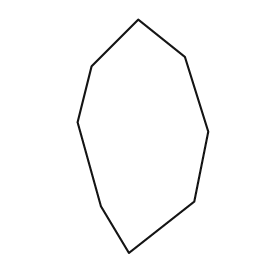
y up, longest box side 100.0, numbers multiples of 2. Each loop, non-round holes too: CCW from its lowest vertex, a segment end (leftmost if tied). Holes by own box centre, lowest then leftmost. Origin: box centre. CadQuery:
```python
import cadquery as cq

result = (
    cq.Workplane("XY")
    .moveTo(-6.0, -50.0)
    .lineTo(22.0, -28.0)
    .lineTo(28.0, 2.0)
    .lineTo(18.0, 34.0)
    .lineTo(-2.0, 50.0)
    .lineTo(-22.0, 30.0)
    .lineTo(-28.0, 6.0)
    .lineTo(-18.0, -30.0)
    .close()
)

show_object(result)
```